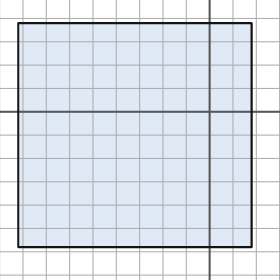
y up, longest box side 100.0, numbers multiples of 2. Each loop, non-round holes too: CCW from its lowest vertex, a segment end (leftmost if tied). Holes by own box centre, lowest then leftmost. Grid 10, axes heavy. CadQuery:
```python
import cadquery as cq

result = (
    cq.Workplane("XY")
    .moveTo(-82.0, -58.0)
    .lineTo(18.0, -58.0)
    .lineTo(18.0, 38.0)
    .lineTo(-82.0, 38.0)
    .close()
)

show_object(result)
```